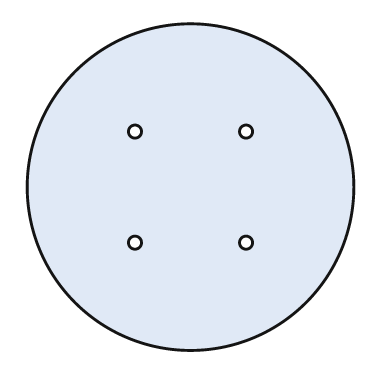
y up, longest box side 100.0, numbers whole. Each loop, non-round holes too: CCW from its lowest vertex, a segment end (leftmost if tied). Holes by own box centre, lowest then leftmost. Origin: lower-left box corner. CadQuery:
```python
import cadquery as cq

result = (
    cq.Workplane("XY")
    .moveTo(50.0, 50.0)
    .circle(50.0)
    .moveTo(33.0, 33.0)
    .circle(2.0)
    .moveTo(67.0, 33.0)
    .circle(2.0)
    .moveTo(33.0, 67.0)
    .circle(2.0)
    .moveTo(67.0, 67.0)
    .circle(2.0)
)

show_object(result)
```